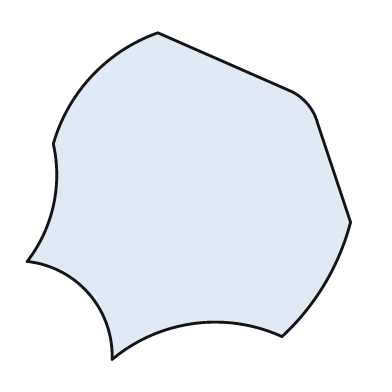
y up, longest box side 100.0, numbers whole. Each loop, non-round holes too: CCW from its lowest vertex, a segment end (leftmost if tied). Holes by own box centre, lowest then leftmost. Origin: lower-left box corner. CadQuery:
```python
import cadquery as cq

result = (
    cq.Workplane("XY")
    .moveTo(26.0, 0.0)
    .threePointArc((51.0, 11.0), (78.0, 7.0))
    .threePointArc((91.0, 23.0), (99.0, 42.0))
    .lineTo(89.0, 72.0)
    .threePointArc((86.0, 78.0), (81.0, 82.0))
    .lineTo(40.0, 100.0)
    .threePointArc((20.0, 87.0), (8.0, 66.0))
    .threePointArc((8.0, 47.0), (0.0, 30.0))
    .threePointArc((19.0, 20.0), (26.0, 0.0))
    .close()
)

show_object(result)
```